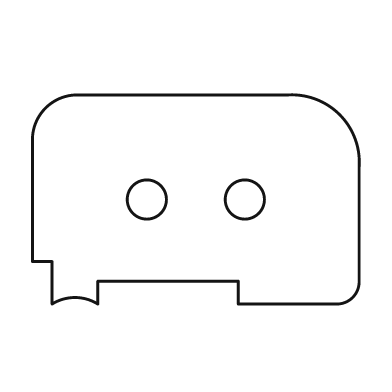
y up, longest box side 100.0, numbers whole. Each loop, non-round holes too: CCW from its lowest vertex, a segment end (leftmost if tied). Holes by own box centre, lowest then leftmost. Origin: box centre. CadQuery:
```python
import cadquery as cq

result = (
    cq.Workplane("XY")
    .moveTo(-44.0, -32.0)
    .threePointArc((-37.0, -30.0), (-30.0, -32.0))
    .lineTo(-30.0, -25.0)
    .lineTo(13.0, -25.0)
    .lineTo(13.0, -32.0)
    .lineTo(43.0, -32.0)
    .threePointArc((48.0, -30.0), (50.0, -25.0))
    .lineTo(50.0, 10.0)
    .threePointArc((44.0, 26.0), (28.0, 32.0))
    .lineTo(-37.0, 32.0)
    .threePointArc((-46.0, 28.0), (-50.0, 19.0))
    .lineTo(-50.0, -19.0)
    .lineTo(-44.0, -19.0)
    .close()
    .moveTo(-15.0, 0.0)
    .circle(6.0)
    .moveTo(15.0, 0.0)
    .circle(6.0)
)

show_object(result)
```